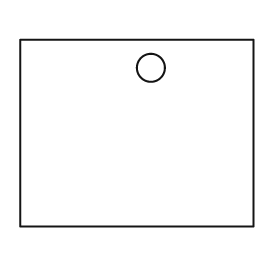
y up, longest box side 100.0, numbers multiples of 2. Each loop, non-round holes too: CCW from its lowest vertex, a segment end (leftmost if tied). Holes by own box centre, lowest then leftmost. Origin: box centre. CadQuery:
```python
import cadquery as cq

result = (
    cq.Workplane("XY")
    .moveTo(-50.0, -40.0)
    .lineTo(50.0, -40.0)
    .lineTo(50.0, 40.0)
    .lineTo(-50.0, 40.0)
    .close()
    .moveTo(6.0, 28.0)
    .circle(6.0)
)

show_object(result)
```